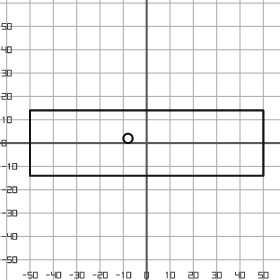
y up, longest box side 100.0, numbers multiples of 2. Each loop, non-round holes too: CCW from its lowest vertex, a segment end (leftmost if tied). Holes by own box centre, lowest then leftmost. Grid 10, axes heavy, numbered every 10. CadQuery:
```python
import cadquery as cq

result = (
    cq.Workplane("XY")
    .moveTo(-50.0, -14.0)
    .lineTo(50.0, -14.0)
    .lineTo(50.0, 14.0)
    .lineTo(-50.0, 14.0)
    .close()
    .moveTo(-8.0, 2.0)
    .circle(2.0)
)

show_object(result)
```